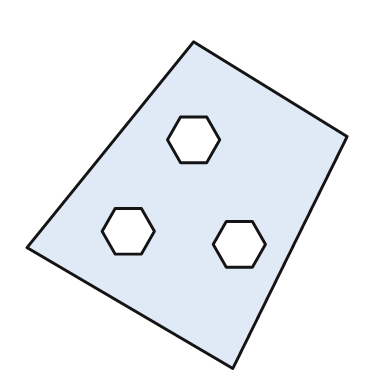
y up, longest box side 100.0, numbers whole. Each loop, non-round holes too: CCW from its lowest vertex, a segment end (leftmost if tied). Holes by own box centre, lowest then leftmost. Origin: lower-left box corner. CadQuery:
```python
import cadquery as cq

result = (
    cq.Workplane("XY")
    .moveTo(63.0, 0.0)
    .lineTo(98.0, 71.0)
    .lineTo(51.0, 100.0)
    .lineTo(0.0, 37.0)
    .close()
    .moveTo(61.0, 31.0)
    .lineTo(69.0, 31.0)
    .lineTo(73.0, 38.0)
    .lineTo(69.0, 45.0)
    .lineTo(61.0, 45.0)
    .lineTo(57.0, 38.0)
    .close()
    .moveTo(27.0, 35.0)
    .lineTo(35.0, 35.0)
    .lineTo(39.0, 42.0)
    .lineTo(35.0, 49.0)
    .lineTo(27.0, 49.0)
    .lineTo(23.0, 42.0)
    .close()
    .moveTo(47.0, 63.0)
    .lineTo(55.0, 63.0)
    .lineTo(59.0, 70.0)
    .lineTo(55.0, 77.0)
    .lineTo(47.0, 77.0)
    .lineTo(43.0, 70.0)
    .close()
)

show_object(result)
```